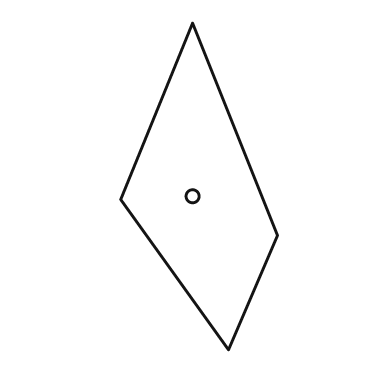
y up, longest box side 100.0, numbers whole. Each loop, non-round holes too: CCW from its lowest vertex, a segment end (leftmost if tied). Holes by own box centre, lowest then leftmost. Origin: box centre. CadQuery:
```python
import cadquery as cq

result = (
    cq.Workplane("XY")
    .moveTo(9.0, -50.0)
    .lineTo(24.0, -15.0)
    .lineTo(-2.0, 50.0)
    .lineTo(-24.0, -4.0)
    .close()
    .moveTo(-2.0, -3.0)
    .circle(2.0)
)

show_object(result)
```